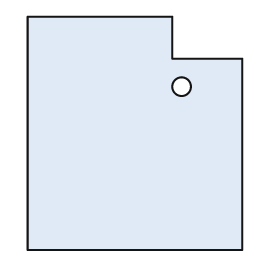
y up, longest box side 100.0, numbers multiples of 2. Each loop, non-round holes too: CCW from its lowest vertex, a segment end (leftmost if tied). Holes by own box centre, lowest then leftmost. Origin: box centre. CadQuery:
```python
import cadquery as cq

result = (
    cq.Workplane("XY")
    .moveTo(-46.0, -50.0)
    .lineTo(46.0, -50.0)
    .lineTo(46.0, 32.0)
    .lineTo(16.0, 32.0)
    .lineTo(16.0, 50.0)
    .lineTo(-46.0, 50.0)
    .close()
    .moveTo(20.0, 20.0)
    .circle(4.0)
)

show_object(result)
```